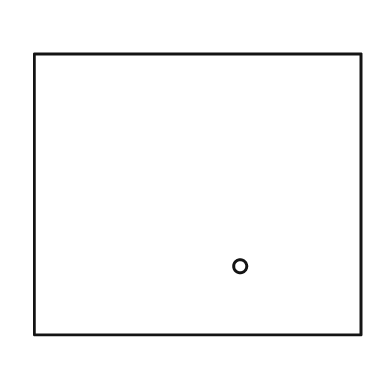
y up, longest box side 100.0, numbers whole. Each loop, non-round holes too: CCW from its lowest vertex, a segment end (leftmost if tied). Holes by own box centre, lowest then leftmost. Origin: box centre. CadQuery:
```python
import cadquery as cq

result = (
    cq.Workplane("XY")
    .moveTo(-50.0, -43.0)
    .lineTo(50.0, -43.0)
    .lineTo(50.0, 43.0)
    .lineTo(-50.0, 43.0)
    .close()
    .moveTo(13.0, -22.0)
    .circle(2.0)
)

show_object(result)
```